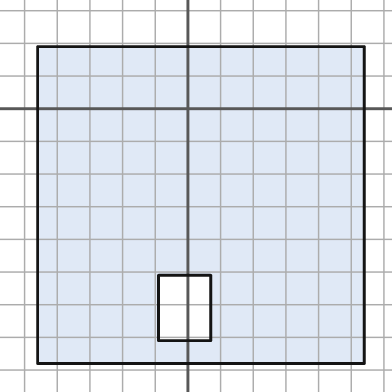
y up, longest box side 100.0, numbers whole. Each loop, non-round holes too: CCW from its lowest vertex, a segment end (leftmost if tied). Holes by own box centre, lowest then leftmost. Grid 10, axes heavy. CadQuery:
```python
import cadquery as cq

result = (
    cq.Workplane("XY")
    .moveTo(-46.0, -78.0)
    .lineTo(54.0, -78.0)
    .lineTo(54.0, 19.0)
    .lineTo(-46.0, 19.0)
    .close()
    .moveTo(-9.0, -71.0)
    .lineTo(7.0, -71.0)
    .lineTo(7.0, -51.0)
    .lineTo(-9.0, -51.0)
    .close()
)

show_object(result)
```